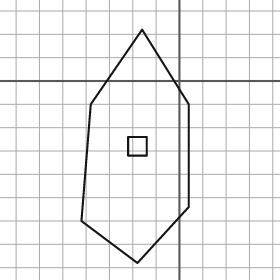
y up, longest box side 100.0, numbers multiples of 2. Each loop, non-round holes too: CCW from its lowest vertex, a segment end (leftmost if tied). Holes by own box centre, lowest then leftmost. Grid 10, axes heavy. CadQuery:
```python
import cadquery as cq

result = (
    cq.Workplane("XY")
    .moveTo(-18.0, -78.0)
    .lineTo(4.0, -54.0)
    .lineTo(4.0, -10.0)
    .lineTo(-16.0, 22.0)
    .lineTo(-38.0, -10.0)
    .lineTo(-42.0, -60.0)
    .close()
    .moveTo(-22.0, -32.0)
    .lineTo(-14.0, -32.0)
    .lineTo(-14.0, -24.0)
    .lineTo(-22.0, -24.0)
    .close()
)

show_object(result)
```